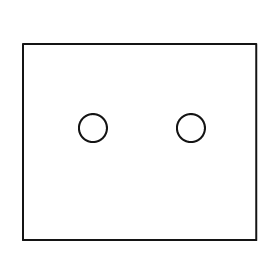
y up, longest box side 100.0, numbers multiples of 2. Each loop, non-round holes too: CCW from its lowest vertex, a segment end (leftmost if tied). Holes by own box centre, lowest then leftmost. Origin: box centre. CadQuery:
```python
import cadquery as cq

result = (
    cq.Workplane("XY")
    .moveTo(-50.0, -42.0)
    .lineTo(50.0, -42.0)
    .lineTo(50.0, 42.0)
    .lineTo(-50.0, 42.0)
    .close()
    .moveTo(-20.0, 6.0)
    .circle(6.0)
    .moveTo(22.0, 6.0)
    .circle(6.0)
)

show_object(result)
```